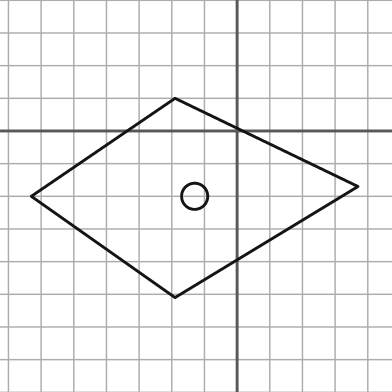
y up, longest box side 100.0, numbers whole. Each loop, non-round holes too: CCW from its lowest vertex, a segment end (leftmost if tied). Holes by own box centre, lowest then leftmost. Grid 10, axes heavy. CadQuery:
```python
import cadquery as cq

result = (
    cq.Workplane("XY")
    .moveTo(-19.0, -51.0)
    .lineTo(37.0, -17.0)
    .lineTo(-19.0, 10.0)
    .lineTo(-63.0, -20.0)
    .close()
    .moveTo(-13.0, -20.0)
    .circle(4.0)
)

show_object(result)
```